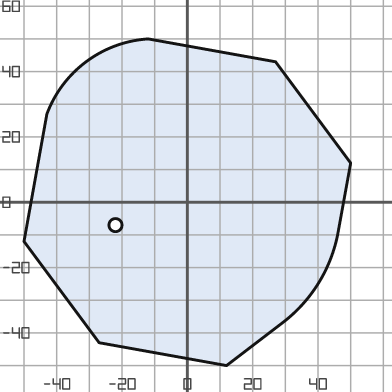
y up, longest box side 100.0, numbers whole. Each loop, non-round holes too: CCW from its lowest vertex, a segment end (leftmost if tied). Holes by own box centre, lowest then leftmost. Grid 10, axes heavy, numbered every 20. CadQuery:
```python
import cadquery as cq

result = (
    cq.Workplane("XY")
    .moveTo(12.0, -50.0)
    .lineTo(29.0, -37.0)
    .threePointArc((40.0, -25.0), (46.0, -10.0))
    .lineTo(50.0, 12.0)
    .lineTo(27.0, 43.0)
    .lineTo(-12.0, 50.0)
    .threePointArc((-31.0, 43.0), (-43.0, 27.0))
    .lineTo(-50.0, -12.0)
    .lineTo(-27.0, -43.0)
    .close()
    .moveTo(-22.0, -7.0)
    .circle(2.0)
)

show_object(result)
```